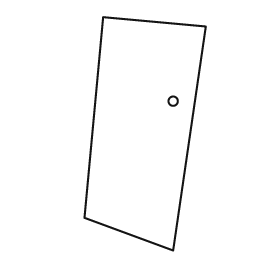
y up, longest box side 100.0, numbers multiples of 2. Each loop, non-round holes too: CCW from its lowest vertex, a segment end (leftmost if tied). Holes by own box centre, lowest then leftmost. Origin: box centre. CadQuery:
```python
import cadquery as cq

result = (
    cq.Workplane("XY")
    .moveTo(12.0, -50.0)
    .lineTo(26.0, 46.0)
    .lineTo(-18.0, 50.0)
    .lineTo(-26.0, -36.0)
    .close()
    .moveTo(12.0, 14.0)
    .circle(2.0)
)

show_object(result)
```